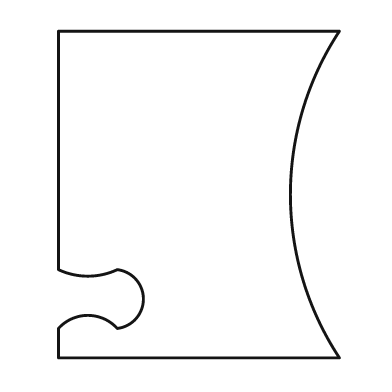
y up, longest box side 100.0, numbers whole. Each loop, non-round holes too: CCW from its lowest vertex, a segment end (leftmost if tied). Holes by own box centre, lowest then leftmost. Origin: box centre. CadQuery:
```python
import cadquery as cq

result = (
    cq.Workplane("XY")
    .moveTo(-43.0, -50.0)
    .lineTo(43.0, -50.0)
    .threePointArc((28.0, 0.0), (43.0, 50.0))
    .lineTo(-43.0, 50.0)
    .lineTo(-43.0, -23.0)
    .threePointArc((-34.0, -25.0), (-25.0, -23.0))
    .threePointArc((-17.0, -32.0), (-25.0, -41.0))
    .threePointArc((-34.0, -37.0), (-43.0, -41.0))
    .close()
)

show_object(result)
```